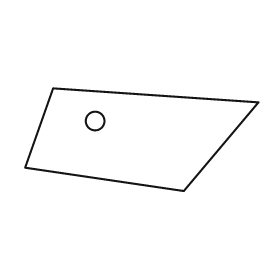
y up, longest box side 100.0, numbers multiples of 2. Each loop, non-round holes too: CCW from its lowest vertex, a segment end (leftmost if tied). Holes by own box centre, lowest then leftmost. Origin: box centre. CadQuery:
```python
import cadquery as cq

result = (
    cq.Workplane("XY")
    .moveTo(18.0, -22.0)
    .lineTo(50.0, 16.0)
    .lineTo(-38.0, 22.0)
    .lineTo(-50.0, -12.0)
    .close()
    .moveTo(-20.0, 8.0)
    .circle(4.0)
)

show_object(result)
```